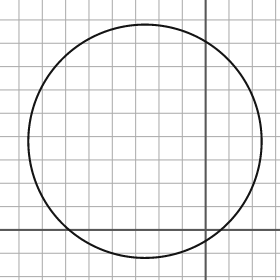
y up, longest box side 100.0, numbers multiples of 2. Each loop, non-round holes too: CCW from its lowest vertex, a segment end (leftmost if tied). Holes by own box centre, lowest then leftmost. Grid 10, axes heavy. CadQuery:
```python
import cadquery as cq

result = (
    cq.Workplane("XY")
    .moveTo(-26.0, 38.0)
    .circle(50.0)
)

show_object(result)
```